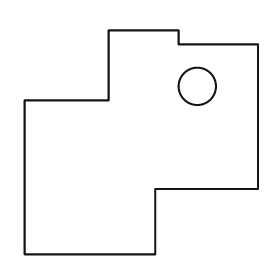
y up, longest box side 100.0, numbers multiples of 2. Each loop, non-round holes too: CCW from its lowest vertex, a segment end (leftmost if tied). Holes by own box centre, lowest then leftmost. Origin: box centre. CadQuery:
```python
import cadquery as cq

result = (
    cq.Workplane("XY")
    .moveTo(-50.0, -48.0)
    .lineTo(6.0, -48.0)
    .lineTo(6.0, -20.0)
    .lineTo(50.0, -20.0)
    .lineTo(50.0, 42.0)
    .lineTo(16.0, 42.0)
    .lineTo(16.0, 48.0)
    .lineTo(-14.0, 48.0)
    .lineTo(-14.0, 18.0)
    .lineTo(-50.0, 18.0)
    .close()
    .moveTo(24.0, 24.0)
    .circle(8.0)
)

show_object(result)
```